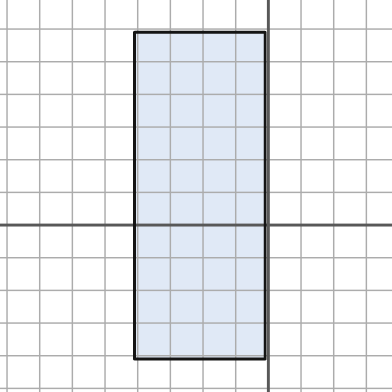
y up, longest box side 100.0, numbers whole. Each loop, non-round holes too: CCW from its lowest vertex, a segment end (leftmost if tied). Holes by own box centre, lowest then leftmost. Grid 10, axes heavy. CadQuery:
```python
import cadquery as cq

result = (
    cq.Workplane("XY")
    .moveTo(-41.0, -41.0)
    .lineTo(-1.0, -41.0)
    .lineTo(-1.0, 59.0)
    .lineTo(-41.0, 59.0)
    .close()
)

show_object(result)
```